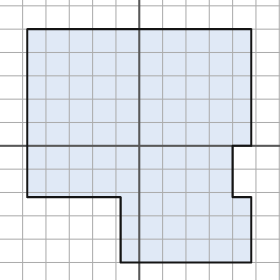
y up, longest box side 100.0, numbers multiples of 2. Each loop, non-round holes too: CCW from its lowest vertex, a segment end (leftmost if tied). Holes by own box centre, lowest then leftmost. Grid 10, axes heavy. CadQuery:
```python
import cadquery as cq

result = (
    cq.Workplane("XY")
    .moveTo(-8.0, -50.0)
    .lineTo(48.0, -50.0)
    .lineTo(48.0, -22.0)
    .lineTo(40.0, -22.0)
    .lineTo(40.0, 0.0)
    .lineTo(48.0, 0.0)
    .lineTo(48.0, 50.0)
    .lineTo(-48.0, 50.0)
    .lineTo(-48.0, -22.0)
    .lineTo(-8.0, -22.0)
    .close()
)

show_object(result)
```